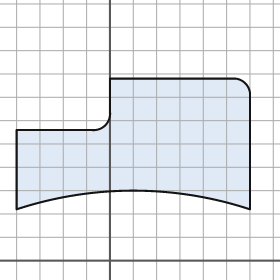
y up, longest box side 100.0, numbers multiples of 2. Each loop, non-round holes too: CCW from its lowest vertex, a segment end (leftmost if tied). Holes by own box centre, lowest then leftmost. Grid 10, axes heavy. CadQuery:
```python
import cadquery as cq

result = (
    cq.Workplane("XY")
    .moveTo(-40.0, 22.0)
    .threePointArc((10.0, 30.0), (60.0, 22.0))
    .lineTo(60.0, 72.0)
    .threePointArc((58.0, 76.0), (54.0, 78.0))
    .lineTo(0.0, 78.0)
    .lineTo(0.0, 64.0)
    .threePointArc((-2.0, 58.0), (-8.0, 56.0))
    .lineTo(-40.0, 56.0)
    .close()
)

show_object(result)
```